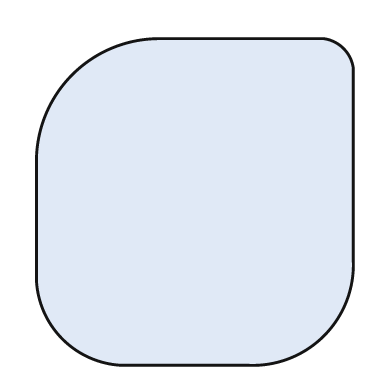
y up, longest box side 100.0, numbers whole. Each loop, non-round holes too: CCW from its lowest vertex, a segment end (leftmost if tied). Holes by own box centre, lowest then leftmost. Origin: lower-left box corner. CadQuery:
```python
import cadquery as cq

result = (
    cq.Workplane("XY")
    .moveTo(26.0, 0.0)
    .lineTo(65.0, 0.0)
    .threePointArc((88.0, 9.0), (97.0, 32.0))
    .lineTo(97.0, 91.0)
    .threePointArc((94.0, 97.0), (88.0, 100.0))
    .lineTo(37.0, 100.0)
    .threePointArc((11.0, 89.0), (0.0, 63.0))
    .lineTo(0.0, 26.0)
    .threePointArc((8.0, 8.0), (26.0, 0.0))
    .close()
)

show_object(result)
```